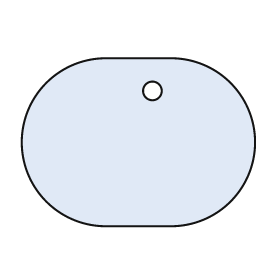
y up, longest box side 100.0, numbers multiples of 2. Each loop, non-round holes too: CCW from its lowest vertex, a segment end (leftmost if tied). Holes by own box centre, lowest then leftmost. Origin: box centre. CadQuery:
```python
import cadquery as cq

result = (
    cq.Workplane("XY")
    .moveTo(-14.0, -36.0)
    .lineTo(14.0, -36.0)
    .threePointArc((50.0, 0.0), (14.0, 36.0))
    .lineTo(-14.0, 36.0)
    .threePointArc((-50.0, 0.0), (-14.0, -36.0))
    .close()
    .moveTo(6.0, 22.0)
    .circle(4.0)
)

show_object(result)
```